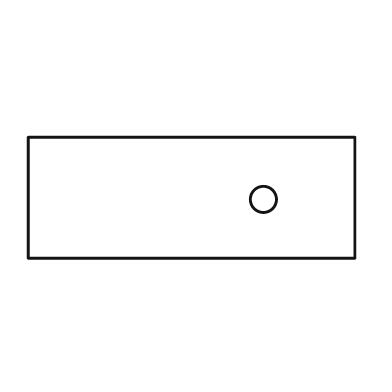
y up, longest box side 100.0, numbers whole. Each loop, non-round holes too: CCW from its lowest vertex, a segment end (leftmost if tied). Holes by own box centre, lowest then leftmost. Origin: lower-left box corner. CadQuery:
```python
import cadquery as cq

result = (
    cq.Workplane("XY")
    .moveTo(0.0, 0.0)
    .lineTo(100.0, 0.0)
    .lineTo(100.0, 37.0)
    .lineTo(0.0, 37.0)
    .close()
    .moveTo(72.0, 18.0)
    .circle(4.0)
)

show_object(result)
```